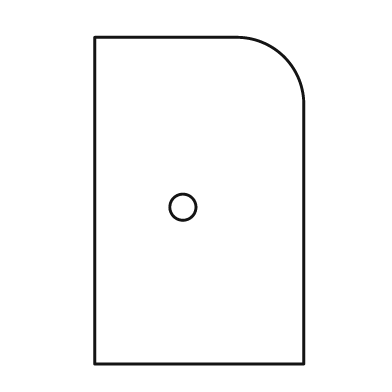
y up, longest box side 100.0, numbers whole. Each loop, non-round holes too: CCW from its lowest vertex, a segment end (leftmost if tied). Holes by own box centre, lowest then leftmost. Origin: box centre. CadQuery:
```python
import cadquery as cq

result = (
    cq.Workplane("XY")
    .moveTo(-32.0, -50.0)
    .lineTo(32.0, -50.0)
    .lineTo(32.0, 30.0)
    .threePointArc((26.0, 44.0), (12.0, 50.0))
    .lineTo(-32.0, 50.0)
    .close()
    .moveTo(-5.0, -2.0)
    .circle(4.0)
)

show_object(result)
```